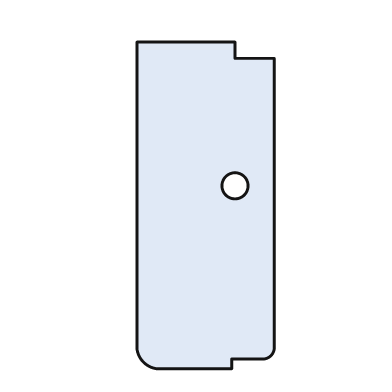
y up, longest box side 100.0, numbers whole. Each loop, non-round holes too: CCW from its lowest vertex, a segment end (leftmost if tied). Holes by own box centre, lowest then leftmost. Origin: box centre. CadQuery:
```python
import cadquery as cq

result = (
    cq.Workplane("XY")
    .moveTo(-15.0, -50.0)
    .lineTo(8.0, -50.0)
    .lineTo(8.0, -47.0)
    .lineTo(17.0, -47.0)
    .threePointArc((20.0, -46.0), (21.0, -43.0))
    .lineTo(21.0, 45.0)
    .lineTo(9.0, 45.0)
    .lineTo(9.0, 50.0)
    .lineTo(-21.0, 50.0)
    .lineTo(-21.0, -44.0)
    .threePointArc((-19.0, -48.0), (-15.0, -50.0))
    .close()
    .moveTo(9.0, 6.0)
    .circle(4.0)
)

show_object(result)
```